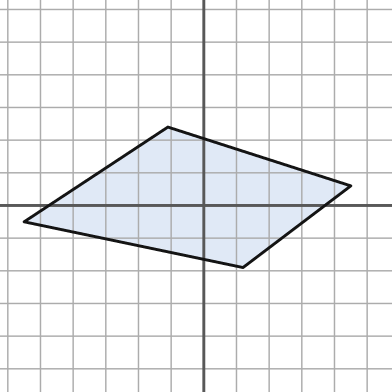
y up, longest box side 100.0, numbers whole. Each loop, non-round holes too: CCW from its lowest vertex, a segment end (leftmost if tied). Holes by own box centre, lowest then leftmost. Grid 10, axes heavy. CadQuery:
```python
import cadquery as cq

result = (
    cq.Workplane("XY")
    .moveTo(12.0, -19.0)
    .lineTo(45.0, 6.0)
    .lineTo(-11.0, 24.0)
    .lineTo(-55.0, -5.0)
    .close()
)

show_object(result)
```